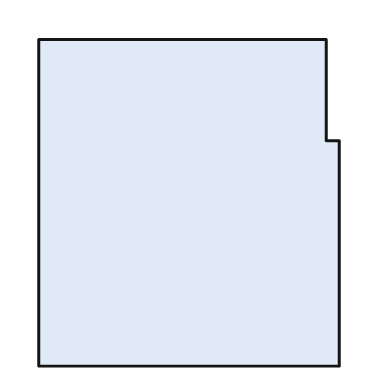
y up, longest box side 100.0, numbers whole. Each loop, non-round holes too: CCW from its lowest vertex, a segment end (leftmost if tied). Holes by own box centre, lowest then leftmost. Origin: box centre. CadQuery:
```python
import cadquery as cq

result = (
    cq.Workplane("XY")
    .moveTo(-46.0, -50.0)
    .lineTo(46.0, -50.0)
    .lineTo(46.0, 19.0)
    .lineTo(42.0, 19.0)
    .lineTo(42.0, 50.0)
    .lineTo(-46.0, 50.0)
    .close()
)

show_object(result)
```